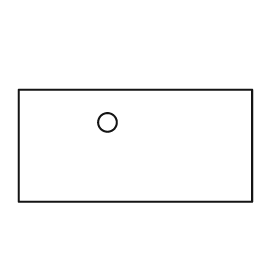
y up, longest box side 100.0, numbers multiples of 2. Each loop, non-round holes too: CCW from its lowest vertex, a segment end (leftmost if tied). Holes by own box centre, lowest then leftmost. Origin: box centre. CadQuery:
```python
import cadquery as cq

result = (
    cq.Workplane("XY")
    .moveTo(-50.0, -24.0)
    .lineTo(50.0, -24.0)
    .lineTo(50.0, 24.0)
    .lineTo(-50.0, 24.0)
    .close()
    .moveTo(-12.0, 10.0)
    .circle(4.0)
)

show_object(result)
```